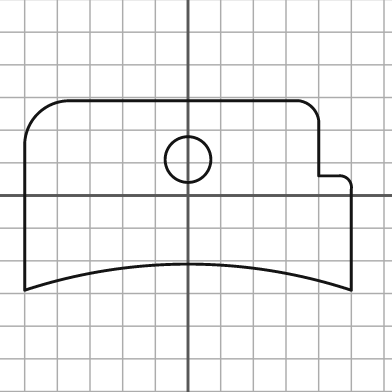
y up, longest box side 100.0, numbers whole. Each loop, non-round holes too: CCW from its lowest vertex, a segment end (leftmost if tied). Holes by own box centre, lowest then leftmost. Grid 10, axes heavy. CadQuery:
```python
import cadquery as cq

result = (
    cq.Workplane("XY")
    .moveTo(-50.0, -29.0)
    .threePointArc((0.0, -21.0), (50.0, -29.0))
    .lineTo(50.0, 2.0)
    .threePointArc((49.0, 5.0), (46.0, 6.0))
    .lineTo(40.0, 6.0)
    .lineTo(40.0, 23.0)
    .threePointArc((38.0, 27.0), (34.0, 29.0))
    .lineTo(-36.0, 29.0)
    .threePointArc((-46.0, 25.0), (-50.0, 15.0))
    .close()
    .moveTo(0.0, 11.0)
    .circle(7.0)
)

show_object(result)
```